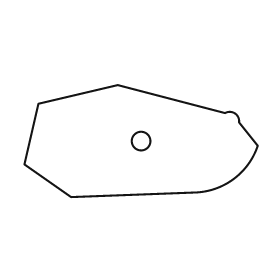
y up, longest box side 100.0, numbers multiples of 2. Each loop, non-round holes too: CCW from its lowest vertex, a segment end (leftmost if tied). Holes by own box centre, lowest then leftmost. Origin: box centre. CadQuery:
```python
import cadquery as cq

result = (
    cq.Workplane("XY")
    .moveTo(-30.0, -24.0)
    .lineTo(24.0, -22.0)
    .threePointArc((40.0, -16.0), (50.0, -2.0))
    .lineTo(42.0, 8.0)
    .threePointArc((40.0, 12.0), (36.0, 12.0))
    .lineTo(-10.0, 24.0)
    .lineTo(-44.0, 16.0)
    .lineTo(-50.0, -10.0)
    .close()
    .moveTo(0.0, 0.0)
    .circle(4.0)
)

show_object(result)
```